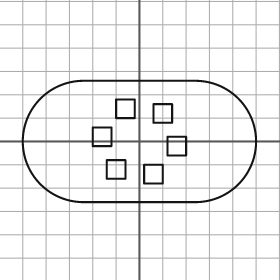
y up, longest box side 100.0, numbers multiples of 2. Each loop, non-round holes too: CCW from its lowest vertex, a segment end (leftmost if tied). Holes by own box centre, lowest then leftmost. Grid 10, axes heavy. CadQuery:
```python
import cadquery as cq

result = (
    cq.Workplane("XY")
    .moveTo(-24.0, -26.0)
    .lineTo(24.0, -26.0)
    .threePointArc((50.0, 0.0), (24.0, 26.0))
    .lineTo(-24.0, 26.0)
    .threePointArc((-50.0, 0.0), (-24.0, -26.0))
    .close()
    .moveTo(2.0, -18.0)
    .lineTo(10.0, -18.0)
    .lineTo(10.0, -10.0)
    .lineTo(2.0, -10.0)
    .close()
    .moveTo(-14.0, -16.0)
    .lineTo(-6.0, -16.0)
    .lineTo(-6.0, -8.0)
    .lineTo(-14.0, -8.0)
    .close()
    .moveTo(12.0, -6.0)
    .lineTo(20.0, -6.0)
    .lineTo(20.0, 2.0)
    .lineTo(12.0, 2.0)
    .close()
    .moveTo(-20.0, -2.0)
    .lineTo(-12.0, -2.0)
    .lineTo(-12.0, 6.0)
    .lineTo(-20.0, 6.0)
    .close()
    .moveTo(6.0, 8.0)
    .lineTo(14.0, 8.0)
    .lineTo(14.0, 16.0)
    .lineTo(6.0, 16.0)
    .close()
    .moveTo(-10.0, 10.0)
    .lineTo(-2.0, 10.0)
    .lineTo(-2.0, 18.0)
    .lineTo(-10.0, 18.0)
    .close()
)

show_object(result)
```